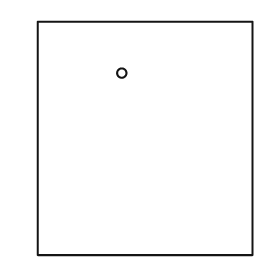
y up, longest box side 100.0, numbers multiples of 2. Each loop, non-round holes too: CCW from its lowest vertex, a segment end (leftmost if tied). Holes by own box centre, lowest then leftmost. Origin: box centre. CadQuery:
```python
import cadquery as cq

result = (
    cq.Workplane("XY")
    .moveTo(-46.0, -50.0)
    .lineTo(46.0, -50.0)
    .lineTo(46.0, 50.0)
    .lineTo(-46.0, 50.0)
    .close()
    .moveTo(-10.0, 28.0)
    .circle(2.0)
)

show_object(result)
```